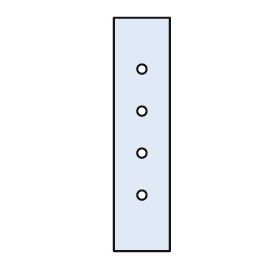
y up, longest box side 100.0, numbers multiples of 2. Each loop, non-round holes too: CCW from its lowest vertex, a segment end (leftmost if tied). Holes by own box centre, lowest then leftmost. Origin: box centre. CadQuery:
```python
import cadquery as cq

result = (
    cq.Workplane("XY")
    .moveTo(-12.0, -50.0)
    .lineTo(12.0, -50.0)
    .lineTo(12.0, 50.0)
    .lineTo(-12.0, 50.0)
    .close()
    .moveTo(0.0, -26.0)
    .circle(2.0)
    .moveTo(0.0, -8.0)
    .circle(2.0)
    .moveTo(0.0, 10.0)
    .circle(2.0)
    .moveTo(0.0, 28.0)
    .circle(2.0)
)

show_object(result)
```